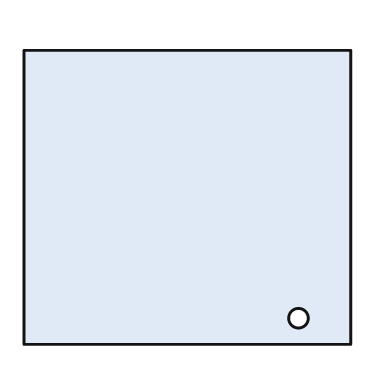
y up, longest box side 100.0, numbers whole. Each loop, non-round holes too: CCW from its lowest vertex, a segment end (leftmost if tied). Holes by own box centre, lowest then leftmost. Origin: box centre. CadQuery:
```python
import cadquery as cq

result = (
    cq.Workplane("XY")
    .moveTo(-50.0, -45.0)
    .lineTo(50.0, -45.0)
    .lineTo(50.0, 45.0)
    .lineTo(-50.0, 45.0)
    .close()
    .moveTo(34.0, -37.0)
    .circle(3.0)
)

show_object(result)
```